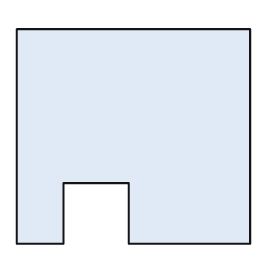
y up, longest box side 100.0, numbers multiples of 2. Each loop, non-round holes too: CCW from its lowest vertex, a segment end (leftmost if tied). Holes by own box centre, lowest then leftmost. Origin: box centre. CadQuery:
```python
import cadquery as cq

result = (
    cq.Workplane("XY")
    .moveTo(-50.0, -46.0)
    .lineTo(-30.0, -46.0)
    .lineTo(-30.0, -20.0)
    .lineTo(-2.0, -20.0)
    .lineTo(-2.0, -46.0)
    .lineTo(50.0, -46.0)
    .lineTo(50.0, 46.0)
    .lineTo(-50.0, 46.0)
    .close()
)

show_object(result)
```